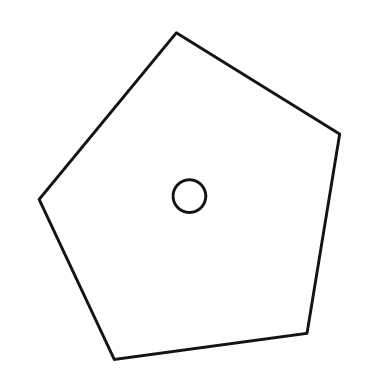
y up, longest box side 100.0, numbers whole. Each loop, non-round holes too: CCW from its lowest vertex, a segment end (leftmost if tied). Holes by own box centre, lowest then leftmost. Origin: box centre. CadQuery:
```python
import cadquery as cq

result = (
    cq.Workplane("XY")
    .moveTo(-23.0, -50.0)
    .lineTo(36.0, -42.0)
    .lineTo(46.0, 19.0)
    .lineTo(-4.0, 50.0)
    .lineTo(-46.0, -1.0)
    .close()
    .moveTo(0.0, 0.0)
    .circle(5.0)
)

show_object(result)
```